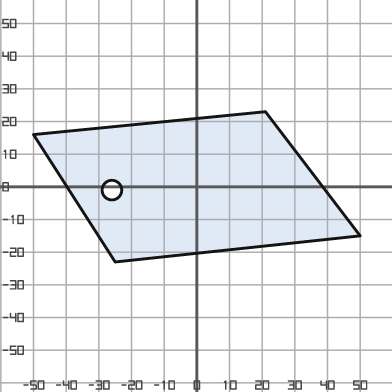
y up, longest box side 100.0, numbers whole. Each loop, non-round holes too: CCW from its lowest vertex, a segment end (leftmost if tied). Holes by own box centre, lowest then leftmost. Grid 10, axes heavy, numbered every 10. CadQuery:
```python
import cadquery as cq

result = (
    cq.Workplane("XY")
    .moveTo(-25.0, -23.0)
    .lineTo(50.0, -15.0)
    .lineTo(21.0, 23.0)
    .lineTo(-50.0, 16.0)
    .close()
    .moveTo(-26.0, -1.0)
    .circle(3.0)
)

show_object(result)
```